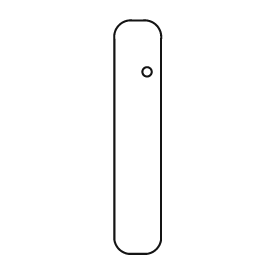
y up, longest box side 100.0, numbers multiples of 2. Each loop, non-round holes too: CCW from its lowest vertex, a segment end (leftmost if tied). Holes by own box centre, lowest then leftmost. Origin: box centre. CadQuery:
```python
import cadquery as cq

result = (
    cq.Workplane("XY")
    .moveTo(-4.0, -50.0)
    .lineTo(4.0, -50.0)
    .threePointArc((8.0, -48.0), (10.0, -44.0))
    .lineTo(10.0, 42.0)
    .threePointArc((8.0, 48.0), (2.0, 50.0))
    .lineTo(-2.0, 50.0)
    .threePointArc((-8.0, 48.0), (-10.0, 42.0))
    .lineTo(-10.0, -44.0)
    .threePointArc((-8.0, -48.0), (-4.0, -50.0))
    .close()
    .moveTo(4.0, 28.0)
    .circle(2.0)
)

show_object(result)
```